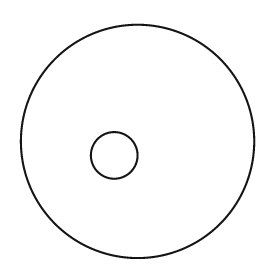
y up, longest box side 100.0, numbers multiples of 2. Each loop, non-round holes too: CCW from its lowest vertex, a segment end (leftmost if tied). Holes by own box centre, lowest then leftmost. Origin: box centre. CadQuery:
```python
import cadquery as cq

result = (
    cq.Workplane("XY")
    .moveTo(0.0, 0.0)
    .circle(50.0)
    .moveTo(-10.0, -6.0)
    .circle(10.0)
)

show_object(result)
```